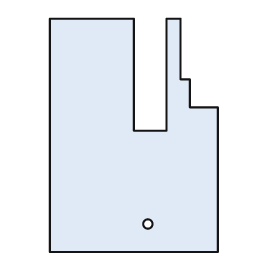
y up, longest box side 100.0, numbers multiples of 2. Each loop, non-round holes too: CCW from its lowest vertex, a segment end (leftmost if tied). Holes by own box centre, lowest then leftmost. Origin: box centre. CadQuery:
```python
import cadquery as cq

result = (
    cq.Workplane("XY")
    .moveTo(-36.0, -50.0)
    .lineTo(36.0, -50.0)
    .lineTo(36.0, 12.0)
    .lineTo(24.0, 12.0)
    .lineTo(24.0, 24.0)
    .lineTo(20.0, 24.0)
    .lineTo(20.0, 50.0)
    .lineTo(14.0, 50.0)
    .lineTo(14.0, 2.0)
    .lineTo(0.0, 2.0)
    .lineTo(0.0, 50.0)
    .lineTo(-36.0, 50.0)
    .close()
    .moveTo(6.0, -38.0)
    .circle(2.0)
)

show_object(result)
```